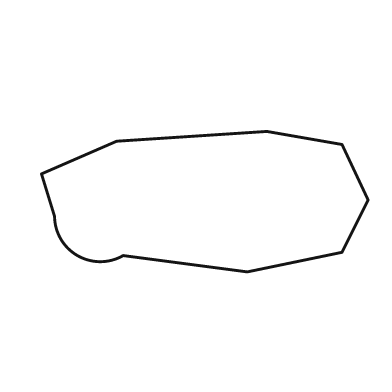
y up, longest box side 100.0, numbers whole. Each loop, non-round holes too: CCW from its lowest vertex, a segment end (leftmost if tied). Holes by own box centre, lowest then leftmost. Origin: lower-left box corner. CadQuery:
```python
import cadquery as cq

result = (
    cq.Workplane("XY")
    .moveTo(63.0, 0.0)
    .lineTo(92.0, 6.0)
    .lineTo(100.0, 22.0)
    .lineTo(92.0, 39.0)
    .lineTo(69.0, 43.0)
    .lineTo(23.0, 40.0)
    .lineTo(0.0, 30.0)
    .lineTo(4.0, 17.0)
    .threePointArc((11.0, 5.0), (25.0, 5.0))
    .close()
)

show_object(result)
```